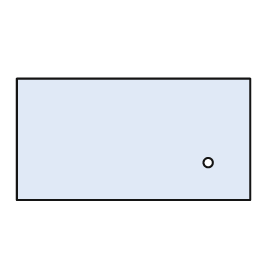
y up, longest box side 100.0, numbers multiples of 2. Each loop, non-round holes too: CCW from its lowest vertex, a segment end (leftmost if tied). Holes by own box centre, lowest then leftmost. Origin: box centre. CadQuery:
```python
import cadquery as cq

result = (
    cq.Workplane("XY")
    .moveTo(-50.0, -26.0)
    .lineTo(50.0, -26.0)
    .lineTo(50.0, 26.0)
    .lineTo(-50.0, 26.0)
    .close()
    .moveTo(32.0, -10.0)
    .circle(2.0)
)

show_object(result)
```